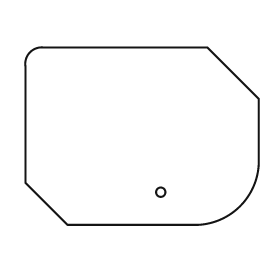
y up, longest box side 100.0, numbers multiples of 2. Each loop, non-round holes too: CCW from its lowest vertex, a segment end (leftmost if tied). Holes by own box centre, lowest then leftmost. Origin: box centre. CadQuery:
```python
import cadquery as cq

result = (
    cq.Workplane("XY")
    .moveTo(-32.0, -38.0)
    .lineTo(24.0, -38.0)
    .threePointArc((42.0, -30.0), (50.0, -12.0))
    .lineTo(50.0, 16.0)
    .lineTo(28.0, 38.0)
    .lineTo(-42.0, 38.0)
    .threePointArc((-48.0, 36.0), (-50.0, 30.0))
    .lineTo(-50.0, -20.0)
    .close()
    .moveTo(8.0, -24.0)
    .circle(2.0)
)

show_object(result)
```